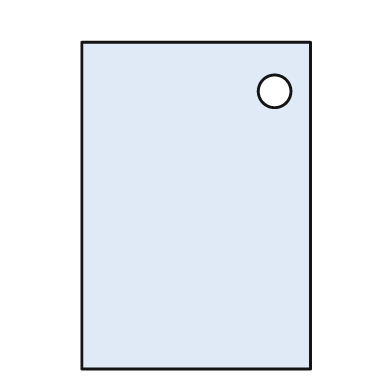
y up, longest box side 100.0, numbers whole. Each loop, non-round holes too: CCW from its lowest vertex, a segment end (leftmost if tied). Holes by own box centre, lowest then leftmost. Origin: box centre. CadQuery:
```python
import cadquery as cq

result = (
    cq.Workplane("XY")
    .moveTo(-35.0, -50.0)
    .lineTo(35.0, -50.0)
    .lineTo(35.0, 50.0)
    .lineTo(-35.0, 50.0)
    .close()
    .moveTo(24.0, 35.0)
    .circle(5.0)
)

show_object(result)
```